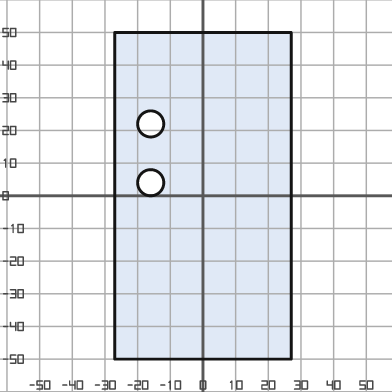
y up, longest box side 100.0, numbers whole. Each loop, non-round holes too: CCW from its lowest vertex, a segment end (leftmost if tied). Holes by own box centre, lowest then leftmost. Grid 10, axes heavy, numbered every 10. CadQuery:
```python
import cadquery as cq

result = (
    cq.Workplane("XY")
    .moveTo(-27.0, -50.0)
    .lineTo(27.0, -50.0)
    .lineTo(27.0, 50.0)
    .lineTo(-27.0, 50.0)
    .close()
    .moveTo(-16.0, 4.0)
    .circle(4.0)
    .moveTo(-16.0, 22.0)
    .circle(4.0)
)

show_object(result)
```